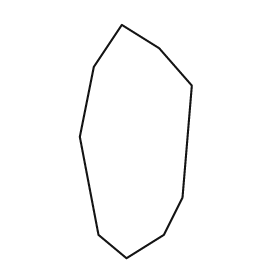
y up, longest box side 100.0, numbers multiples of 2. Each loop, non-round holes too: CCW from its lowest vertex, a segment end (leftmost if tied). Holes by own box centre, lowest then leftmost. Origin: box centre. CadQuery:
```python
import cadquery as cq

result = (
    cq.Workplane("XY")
    .moveTo(-4.0, -50.0)
    .lineTo(12.0, -40.0)
    .lineTo(20.0, -24.0)
    .lineTo(24.0, 24.0)
    .lineTo(10.0, 40.0)
    .lineTo(-6.0, 50.0)
    .lineTo(-18.0, 32.0)
    .lineTo(-24.0, 2.0)
    .lineTo(-16.0, -40.0)
    .close()
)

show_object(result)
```